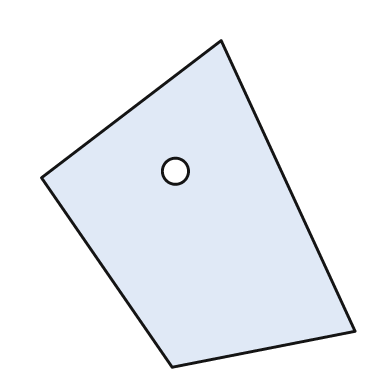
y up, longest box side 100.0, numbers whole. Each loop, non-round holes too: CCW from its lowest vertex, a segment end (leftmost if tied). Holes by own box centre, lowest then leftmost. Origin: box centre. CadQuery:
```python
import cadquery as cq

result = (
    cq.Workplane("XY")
    .moveTo(-8.0, -50.0)
    .lineTo(48.0, -39.0)
    .lineTo(7.0, 50.0)
    .lineTo(-48.0, 8.0)
    .close()
    .moveTo(-7.0, 10.0)
    .circle(4.0)
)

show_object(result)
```